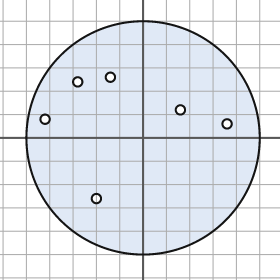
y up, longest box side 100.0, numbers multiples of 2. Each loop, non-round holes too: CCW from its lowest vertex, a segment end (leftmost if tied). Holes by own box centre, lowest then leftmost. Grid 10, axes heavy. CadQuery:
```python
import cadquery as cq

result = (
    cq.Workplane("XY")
    .moveTo(0.0, 0.0)
    .circle(50.0)
    .moveTo(-20.0, -26.0)
    .circle(2.0)
    .moveTo(36.0, 6.0)
    .circle(2.0)
    .moveTo(-42.0, 8.0)
    .circle(2.0)
    .moveTo(16.0, 12.0)
    .circle(2.0)
    .moveTo(-28.0, 24.0)
    .circle(2.0)
    .moveTo(-14.0, 26.0)
    .circle(2.0)
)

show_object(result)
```